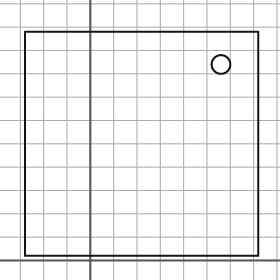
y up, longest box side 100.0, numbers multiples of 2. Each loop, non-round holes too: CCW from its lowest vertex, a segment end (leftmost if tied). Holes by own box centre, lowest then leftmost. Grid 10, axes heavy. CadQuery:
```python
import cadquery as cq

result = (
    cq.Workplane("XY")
    .moveTo(-28.0, 2.0)
    .lineTo(72.0, 2.0)
    .lineTo(72.0, 98.0)
    .lineTo(-28.0, 98.0)
    .close()
    .moveTo(56.0, 84.0)
    .circle(4.0)
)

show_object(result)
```